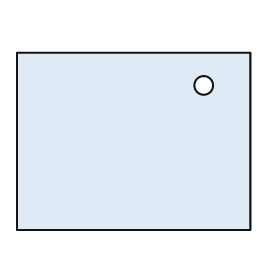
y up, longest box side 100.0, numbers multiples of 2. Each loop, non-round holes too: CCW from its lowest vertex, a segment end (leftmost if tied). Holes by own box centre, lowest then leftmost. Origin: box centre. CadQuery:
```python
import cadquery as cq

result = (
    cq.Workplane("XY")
    .moveTo(-50.0, -38.0)
    .lineTo(50.0, -38.0)
    .lineTo(50.0, 38.0)
    .lineTo(-50.0, 38.0)
    .close()
    .moveTo(30.0, 24.0)
    .circle(4.0)
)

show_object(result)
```